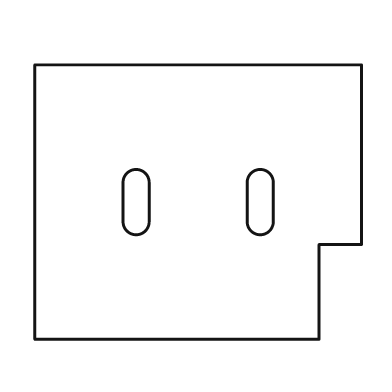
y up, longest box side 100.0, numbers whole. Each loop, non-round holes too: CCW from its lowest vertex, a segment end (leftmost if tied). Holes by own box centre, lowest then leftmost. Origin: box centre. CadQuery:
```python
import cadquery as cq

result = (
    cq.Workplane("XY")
    .moveTo(-50.0, -42.0)
    .lineTo(37.0, -42.0)
    .lineTo(37.0, -13.0)
    .lineTo(50.0, -13.0)
    .lineTo(50.0, 42.0)
    .lineTo(-50.0, 42.0)
    .close()
    .moveTo(-23.0, -6.0)
    .threePointArc((-19.0, -10.0), (-15.0, -6.0))
    .lineTo(-15.0, 6.0)
    .threePointArc((-19.0, 10.0), (-23.0, 6.0))
    .close()
    .moveTo(15.0, -6.0)
    .threePointArc((19.0, -10.0), (23.0, -6.0))
    .lineTo(23.0, 6.0)
    .threePointArc((19.0, 10.0), (15.0, 6.0))
    .close()
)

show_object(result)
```